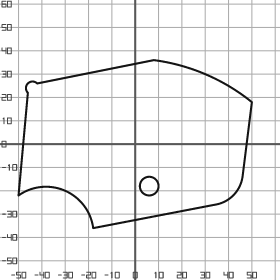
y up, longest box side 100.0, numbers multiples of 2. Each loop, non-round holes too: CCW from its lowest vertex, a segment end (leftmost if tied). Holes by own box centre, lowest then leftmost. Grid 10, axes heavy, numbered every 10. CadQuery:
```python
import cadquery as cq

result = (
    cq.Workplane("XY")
    .moveTo(-18.0, -36.0)
    .lineTo(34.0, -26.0)
    .threePointArc((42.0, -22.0), (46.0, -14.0))
    .lineTo(50.0, 18.0)
    .threePointArc((30.0, 30.0), (8.0, 36.0))
    .lineTo(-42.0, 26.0)
    .threePointArc((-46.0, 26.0), (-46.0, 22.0))
    .lineTo(-50.0, -22.0)
    .threePointArc((-30.0, -20.0), (-18.0, -36.0))
    .close()
    .moveTo(6.0, -18.0)
    .circle(4.0)
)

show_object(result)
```